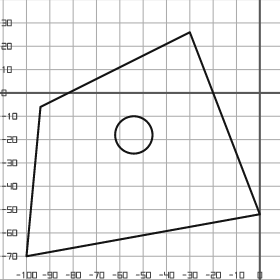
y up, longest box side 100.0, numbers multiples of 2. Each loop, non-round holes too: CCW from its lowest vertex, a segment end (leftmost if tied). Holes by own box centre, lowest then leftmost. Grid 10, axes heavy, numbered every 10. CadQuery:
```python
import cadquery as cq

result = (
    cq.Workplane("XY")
    .moveTo(-100.0, -70.0)
    .lineTo(0.0, -52.0)
    .lineTo(-30.0, 26.0)
    .lineTo(-94.0, -6.0)
    .close()
    .moveTo(-54.0, -18.0)
    .circle(8.0)
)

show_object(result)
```